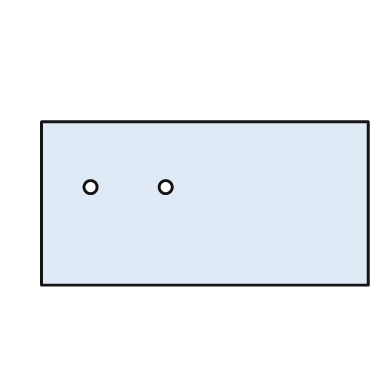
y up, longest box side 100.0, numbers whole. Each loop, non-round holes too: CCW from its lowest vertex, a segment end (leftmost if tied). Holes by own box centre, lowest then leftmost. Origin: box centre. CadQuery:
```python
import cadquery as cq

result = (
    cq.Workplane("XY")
    .moveTo(-50.0, -25.0)
    .lineTo(50.0, -25.0)
    .lineTo(50.0, 25.0)
    .lineTo(-50.0, 25.0)
    .close()
    .moveTo(-35.0, 5.0)
    .circle(2.0)
    .moveTo(-12.0, 5.0)
    .circle(2.0)
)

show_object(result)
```